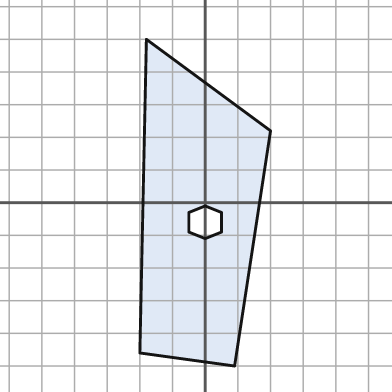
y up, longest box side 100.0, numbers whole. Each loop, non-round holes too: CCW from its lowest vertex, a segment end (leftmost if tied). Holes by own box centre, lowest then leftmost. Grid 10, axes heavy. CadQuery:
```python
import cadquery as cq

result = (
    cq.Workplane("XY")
    .moveTo(9.0, -50.0)
    .lineTo(20.0, 22.0)
    .lineTo(-18.0, 50.0)
    .lineTo(-20.0, -46.0)
    .close()
    .moveTo(0.0, -11.0)
    .lineTo(5.0, -9.0)
    .lineTo(5.0, -3.0)
    .lineTo(0.0, -1.0)
    .lineTo(-5.0, -3.0)
    .lineTo(-5.0, -9.0)
    .close()
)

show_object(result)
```